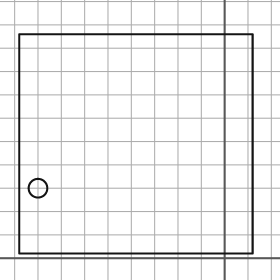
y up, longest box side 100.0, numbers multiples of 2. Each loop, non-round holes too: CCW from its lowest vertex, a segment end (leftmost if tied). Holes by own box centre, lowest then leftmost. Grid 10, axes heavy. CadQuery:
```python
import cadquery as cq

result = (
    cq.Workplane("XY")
    .moveTo(-88.0, 2.0)
    .lineTo(12.0, 2.0)
    .lineTo(12.0, 96.0)
    .lineTo(-88.0, 96.0)
    .close()
    .moveTo(-80.0, 30.0)
    .circle(4.0)
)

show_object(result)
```